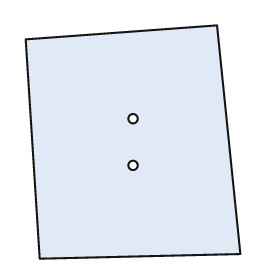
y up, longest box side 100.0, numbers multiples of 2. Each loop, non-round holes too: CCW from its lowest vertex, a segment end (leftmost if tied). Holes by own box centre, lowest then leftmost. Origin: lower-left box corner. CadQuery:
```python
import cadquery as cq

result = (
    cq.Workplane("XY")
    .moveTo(6.0, 0.0)
    .lineTo(92.0, 2.0)
    .lineTo(82.0, 100.0)
    .lineTo(0.0, 94.0)
    .close()
    .moveTo(46.0, 40.0)
    .circle(2.0)
    .moveTo(46.0, 60.0)
    .circle(2.0)
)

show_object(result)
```